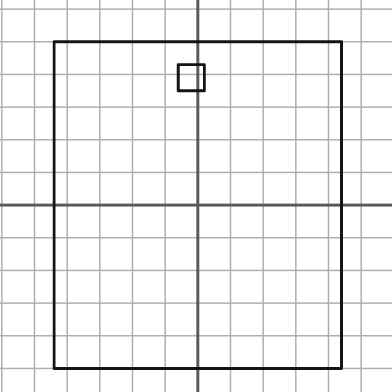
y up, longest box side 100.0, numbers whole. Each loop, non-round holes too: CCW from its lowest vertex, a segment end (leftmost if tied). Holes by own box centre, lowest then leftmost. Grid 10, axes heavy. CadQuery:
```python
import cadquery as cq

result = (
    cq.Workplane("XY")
    .moveTo(-44.0, -50.0)
    .lineTo(44.0, -50.0)
    .lineTo(44.0, 50.0)
    .lineTo(-44.0, 50.0)
    .close()
    .moveTo(-6.0, 35.0)
    .lineTo(2.0, 35.0)
    .lineTo(2.0, 43.0)
    .lineTo(-6.0, 43.0)
    .close()
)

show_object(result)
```